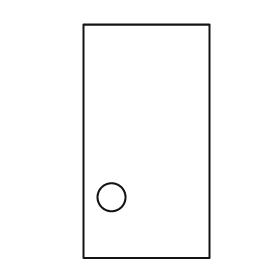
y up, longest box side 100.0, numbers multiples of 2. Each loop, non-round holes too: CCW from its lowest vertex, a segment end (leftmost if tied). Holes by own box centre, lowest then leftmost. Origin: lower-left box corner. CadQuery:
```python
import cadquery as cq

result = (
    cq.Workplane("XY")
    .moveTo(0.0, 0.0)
    .lineTo(54.0, 0.0)
    .lineTo(54.0, 100.0)
    .lineTo(0.0, 100.0)
    .close()
    .moveTo(12.0, 26.0)
    .circle(6.0)
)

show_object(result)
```